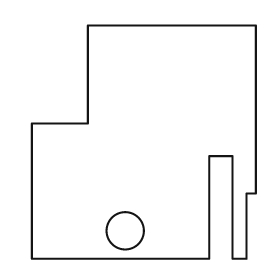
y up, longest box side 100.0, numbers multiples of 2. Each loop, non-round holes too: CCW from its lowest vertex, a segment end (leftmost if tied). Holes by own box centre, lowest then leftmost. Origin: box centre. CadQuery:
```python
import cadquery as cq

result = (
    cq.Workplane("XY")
    .moveTo(-48.0, -50.0)
    .lineTo(28.0, -50.0)
    .lineTo(28.0, -6.0)
    .lineTo(38.0, -6.0)
    .lineTo(38.0, -50.0)
    .lineTo(44.0, -50.0)
    .lineTo(44.0, -22.0)
    .lineTo(48.0, -22.0)
    .lineTo(48.0, 50.0)
    .lineTo(-24.0, 50.0)
    .lineTo(-24.0, 8.0)
    .lineTo(-48.0, 8.0)
    .close()
    .moveTo(-8.0, -38.0)
    .circle(8.0)
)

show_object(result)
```